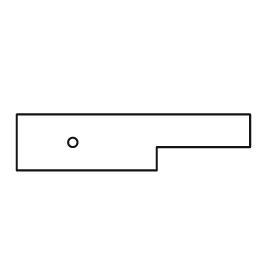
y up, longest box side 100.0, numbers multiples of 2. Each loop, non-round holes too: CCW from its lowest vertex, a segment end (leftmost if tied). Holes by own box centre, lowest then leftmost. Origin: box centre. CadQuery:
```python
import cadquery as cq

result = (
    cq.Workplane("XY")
    .moveTo(-50.0, -12.0)
    .lineTo(10.0, -12.0)
    .lineTo(10.0, -2.0)
    .lineTo(50.0, -2.0)
    .lineTo(50.0, 12.0)
    .lineTo(-50.0, 12.0)
    .close()
    .moveTo(-26.0, 0.0)
    .circle(2.0)
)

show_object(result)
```